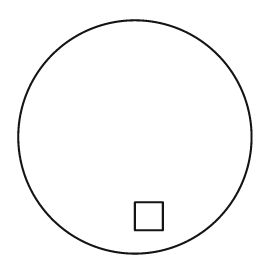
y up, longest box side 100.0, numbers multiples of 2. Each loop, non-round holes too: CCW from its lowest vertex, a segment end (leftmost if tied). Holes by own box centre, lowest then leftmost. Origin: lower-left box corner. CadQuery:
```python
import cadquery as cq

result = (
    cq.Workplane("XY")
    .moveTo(50.0, 50.0)
    .circle(50.0)
    .moveTo(50.0, 10.0)
    .lineTo(62.0, 10.0)
    .lineTo(62.0, 22.0)
    .lineTo(50.0, 22.0)
    .close()
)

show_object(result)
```